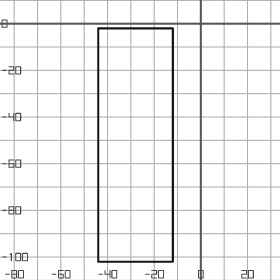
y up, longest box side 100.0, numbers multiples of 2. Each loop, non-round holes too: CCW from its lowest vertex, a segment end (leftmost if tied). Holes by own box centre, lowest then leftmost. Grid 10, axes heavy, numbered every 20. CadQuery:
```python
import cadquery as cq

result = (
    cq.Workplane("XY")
    .moveTo(-44.0, -102.0)
    .lineTo(-12.0, -102.0)
    .lineTo(-12.0, -2.0)
    .lineTo(-44.0, -2.0)
    .close()
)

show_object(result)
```